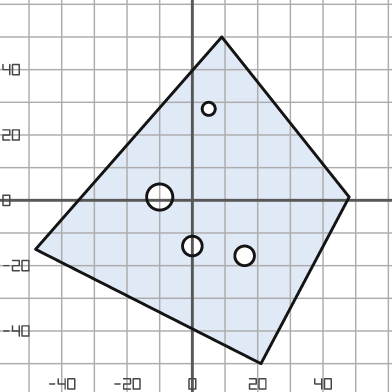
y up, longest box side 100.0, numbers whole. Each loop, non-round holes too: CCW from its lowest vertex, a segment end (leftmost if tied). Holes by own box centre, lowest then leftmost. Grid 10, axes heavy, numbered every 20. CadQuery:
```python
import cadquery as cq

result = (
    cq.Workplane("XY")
    .moveTo(21.0, -50.0)
    .lineTo(48.0, 1.0)
    .lineTo(9.0, 50.0)
    .lineTo(-48.0, -15.0)
    .close()
    .moveTo(16.0, -17.0)
    .circle(3.0)
    .moveTo(0.0, -14.0)
    .circle(3.0)
    .moveTo(-10.0, 1.0)
    .circle(4.0)
    .moveTo(5.0, 28.0)
    .circle(2.0)
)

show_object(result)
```